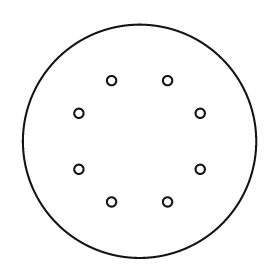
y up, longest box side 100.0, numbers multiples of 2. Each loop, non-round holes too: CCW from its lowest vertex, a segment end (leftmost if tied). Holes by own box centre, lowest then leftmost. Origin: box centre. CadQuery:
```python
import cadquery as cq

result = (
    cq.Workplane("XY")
    .moveTo(0.0, 0.0)
    .circle(50.0)
    .moveTo(-12.0, -26.0)
    .circle(2.0)
    .moveTo(12.0, -26.0)
    .circle(2.0)
    .moveTo(-26.0, -12.0)
    .circle(2.0)
    .moveTo(26.0, -12.0)
    .circle(2.0)
    .moveTo(-26.0, 12.0)
    .circle(2.0)
    .moveTo(26.0, 12.0)
    .circle(2.0)
    .moveTo(-12.0, 26.0)
    .circle(2.0)
    .moveTo(12.0, 26.0)
    .circle(2.0)
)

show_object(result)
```